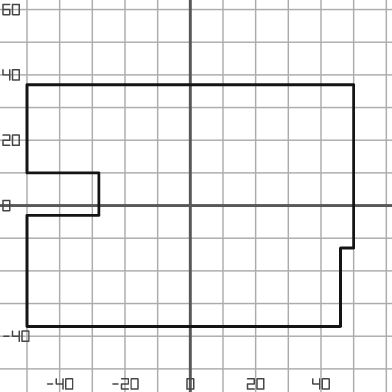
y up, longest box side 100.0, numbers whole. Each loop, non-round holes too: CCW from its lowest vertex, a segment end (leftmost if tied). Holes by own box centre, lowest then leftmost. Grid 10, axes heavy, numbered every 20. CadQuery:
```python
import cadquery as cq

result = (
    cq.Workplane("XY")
    .moveTo(-50.0, -37.0)
    .lineTo(46.0, -37.0)
    .lineTo(46.0, -13.0)
    .lineTo(50.0, -13.0)
    .lineTo(50.0, 37.0)
    .lineTo(-50.0, 37.0)
    .lineTo(-50.0, 10.0)
    .lineTo(-28.0, 10.0)
    .lineTo(-28.0, -3.0)
    .lineTo(-50.0, -3.0)
    .close()
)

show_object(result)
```